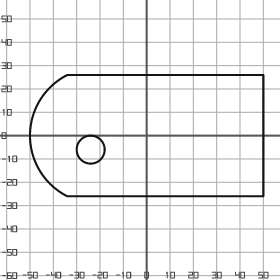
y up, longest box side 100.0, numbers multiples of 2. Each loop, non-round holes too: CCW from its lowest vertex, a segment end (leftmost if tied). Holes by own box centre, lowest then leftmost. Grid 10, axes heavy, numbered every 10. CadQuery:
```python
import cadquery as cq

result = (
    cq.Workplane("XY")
    .moveTo(-34.0, -26.0)
    .lineTo(50.0, -26.0)
    .lineTo(50.0, 26.0)
    .lineTo(-34.0, 26.0)
    .threePointArc((-50.0, 0.0), (-34.0, -26.0))
    .close()
    .moveTo(-24.0, -6.0)
    .circle(6.0)
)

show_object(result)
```